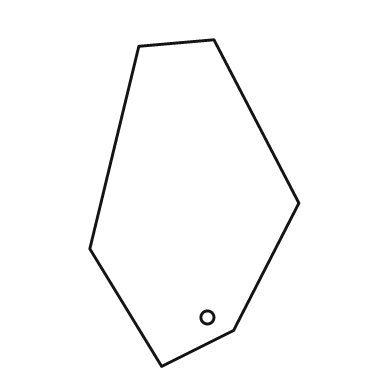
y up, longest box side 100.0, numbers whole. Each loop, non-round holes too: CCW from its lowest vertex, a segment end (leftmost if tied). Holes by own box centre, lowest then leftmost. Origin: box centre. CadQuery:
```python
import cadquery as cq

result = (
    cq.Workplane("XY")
    .moveTo(-10.0, -50.0)
    .lineTo(12.0, -39.0)
    .lineTo(32.0, 0.0)
    .lineTo(6.0, 50.0)
    .lineTo(-17.0, 48.0)
    .lineTo(-32.0, -14.0)
    .close()
    .moveTo(4.0, -35.0)
    .circle(2.0)
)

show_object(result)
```